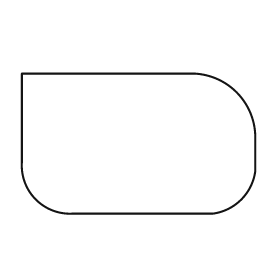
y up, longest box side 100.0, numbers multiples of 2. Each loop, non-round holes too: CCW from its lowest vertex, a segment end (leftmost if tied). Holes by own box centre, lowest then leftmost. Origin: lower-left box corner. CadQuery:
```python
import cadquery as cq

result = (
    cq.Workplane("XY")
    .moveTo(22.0, 0.0)
    .lineTo(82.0, 0.0)
    .threePointArc((94.0, 6.0), (100.0, 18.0))
    .lineTo(100.0, 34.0)
    .threePointArc((92.0, 52.0), (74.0, 60.0))
    .lineTo(0.0, 60.0)
    .lineTo(0.0, 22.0)
    .threePointArc((6.0, 6.0), (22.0, 0.0))
    .close()
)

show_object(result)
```